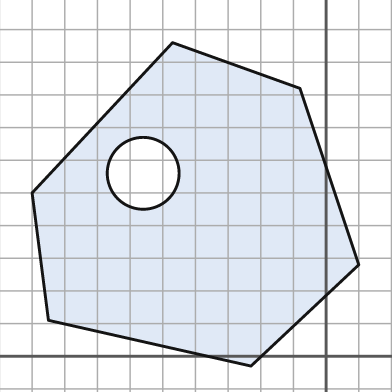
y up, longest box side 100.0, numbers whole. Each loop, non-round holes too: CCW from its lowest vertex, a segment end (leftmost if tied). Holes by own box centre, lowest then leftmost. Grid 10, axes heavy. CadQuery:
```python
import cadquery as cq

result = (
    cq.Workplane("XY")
    .moveTo(-23.0, -3.0)
    .lineTo(10.0, 28.0)
    .lineTo(-8.0, 82.0)
    .lineTo(-47.0, 96.0)
    .lineTo(-90.0, 50.0)
    .lineTo(-85.0, 11.0)
    .close()
    .moveTo(-56.0, 56.0)
    .circle(11.0)
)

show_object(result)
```